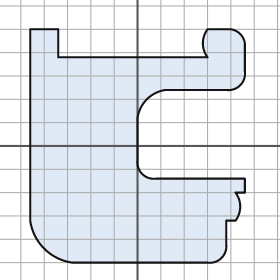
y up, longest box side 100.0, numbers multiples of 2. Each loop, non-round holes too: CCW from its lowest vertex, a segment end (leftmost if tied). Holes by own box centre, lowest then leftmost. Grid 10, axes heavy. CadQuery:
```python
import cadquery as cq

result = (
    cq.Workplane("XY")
    .moveTo(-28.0, -50.0)
    .lineTo(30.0, -50.0)
    .threePointArc((36.0, -48.0), (38.0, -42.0))
    .lineTo(38.0, -32.0)
    .lineTo(42.0, -32.0)
    .threePointArc((44.0, -26.0), (42.0, -20.0))
    .lineTo(46.0, -20.0)
    .lineTo(46.0, -14.0)
    .lineTo(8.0, -14.0)
    .threePointArc((2.0, -12.0), (0.0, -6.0))
    .lineTo(0.0, 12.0)
    .threePointArc((4.0, 20.0), (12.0, 24.0))
    .lineTo(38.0, 24.0)
    .threePointArc((44.0, 26.0), (46.0, 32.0))
    .lineTo(46.0, 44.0)
    .threePointArc((44.0, 48.0), (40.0, 50.0))
    .lineTo(30.0, 50.0)
    .threePointArc((28.0, 44.0), (30.0, 38.0))
    .lineTo(-34.0, 38.0)
    .lineTo(-34.0, 50.0)
    .lineTo(-46.0, 50.0)
    .lineTo(-46.0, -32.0)
    .threePointArc((-40.0, -44.0), (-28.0, -50.0))
    .close()
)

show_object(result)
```